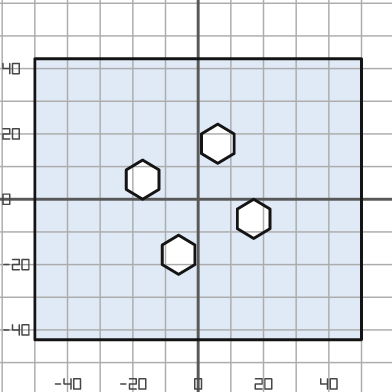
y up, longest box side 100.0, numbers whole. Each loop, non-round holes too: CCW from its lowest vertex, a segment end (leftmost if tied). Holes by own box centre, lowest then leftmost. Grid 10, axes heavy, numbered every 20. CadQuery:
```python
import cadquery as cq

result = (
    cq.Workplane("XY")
    .moveTo(-50.0, -43.0)
    .lineTo(50.0, -43.0)
    .lineTo(50.0, 43.0)
    .lineTo(-50.0, 43.0)
    .close()
    .moveTo(-6.0, -23.0)
    .lineTo(-1.0, -20.0)
    .lineTo(-1.0, -14.0)
    .lineTo(-6.0, -11.0)
    .lineTo(-11.0, -14.0)
    .lineTo(-11.0, -20.0)
    .close()
    .moveTo(17.0, -12.0)
    .lineTo(22.0, -9.0)
    .lineTo(22.0, -3.0)
    .lineTo(17.0, 0.0)
    .lineTo(12.0, -3.0)
    .lineTo(12.0, -9.0)
    .close()
    .moveTo(-17.0, 0.0)
    .lineTo(-12.0, 3.0)
    .lineTo(-12.0, 9.0)
    .lineTo(-17.0, 12.0)
    .lineTo(-22.0, 9.0)
    .lineTo(-22.0, 3.0)
    .close()
    .moveTo(6.0, 11.0)
    .lineTo(11.0, 14.0)
    .lineTo(11.0, 20.0)
    .lineTo(6.0, 23.0)
    .lineTo(1.0, 20.0)
    .lineTo(1.0, 14.0)
    .close()
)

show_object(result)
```